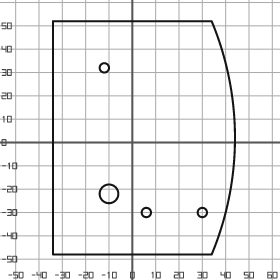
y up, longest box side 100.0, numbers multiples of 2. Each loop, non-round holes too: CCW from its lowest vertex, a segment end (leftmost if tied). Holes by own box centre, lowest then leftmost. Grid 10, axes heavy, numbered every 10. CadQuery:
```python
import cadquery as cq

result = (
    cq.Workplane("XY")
    .moveTo(-34.0, -48.0)
    .lineTo(34.0, -48.0)
    .threePointArc((44.0, 2.0), (34.0, 52.0))
    .lineTo(-34.0, 52.0)
    .close()
    .moveTo(6.0, -30.0)
    .circle(2.0)
    .moveTo(30.0, -30.0)
    .circle(2.0)
    .moveTo(-10.0, -22.0)
    .circle(4.0)
    .moveTo(-12.0, 32.0)
    .circle(2.0)
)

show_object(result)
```